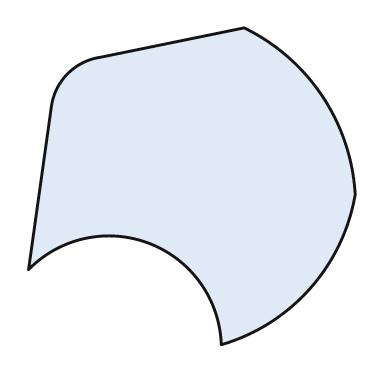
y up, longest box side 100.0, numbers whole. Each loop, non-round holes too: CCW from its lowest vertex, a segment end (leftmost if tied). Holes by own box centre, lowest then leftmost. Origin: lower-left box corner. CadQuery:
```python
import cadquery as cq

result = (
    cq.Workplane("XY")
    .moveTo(59.0, 0.0)
    .threePointArc((86.0, 17.0), (100.0, 46.0))
    .threePointArc((90.0, 76.0), (66.0, 97.0))
    .lineTo(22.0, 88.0)
    .threePointArc((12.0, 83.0), (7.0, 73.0))
    .lineTo(0.0, 23.0)
    .threePointArc((37.0, 31.0), (59.0, 0.0))
    .close()
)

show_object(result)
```